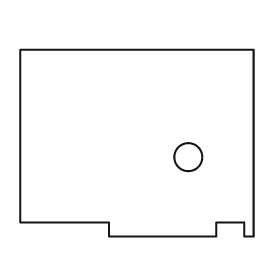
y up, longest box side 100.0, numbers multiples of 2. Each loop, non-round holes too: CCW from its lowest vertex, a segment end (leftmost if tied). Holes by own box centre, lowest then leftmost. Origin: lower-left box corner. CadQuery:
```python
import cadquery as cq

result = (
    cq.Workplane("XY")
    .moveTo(38.0, 0.0)
    .lineTo(84.0, 0.0)
    .lineTo(84.0, 6.0)
    .lineTo(96.0, 6.0)
    .lineTo(96.0, 0.0)
    .lineTo(100.0, 0.0)
    .lineTo(100.0, 80.0)
    .lineTo(0.0, 80.0)
    .lineTo(0.0, 6.0)
    .lineTo(38.0, 6.0)
    .close()
    .moveTo(72.0, 34.0)
    .circle(6.0)
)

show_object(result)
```